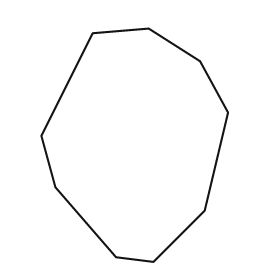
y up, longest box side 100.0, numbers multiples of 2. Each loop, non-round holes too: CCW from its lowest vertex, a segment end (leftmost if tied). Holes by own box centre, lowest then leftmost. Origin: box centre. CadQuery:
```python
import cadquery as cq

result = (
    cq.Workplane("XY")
    .moveTo(8.0, -50.0)
    .lineTo(30.0, -28.0)
    .lineTo(40.0, 14.0)
    .lineTo(28.0, 36.0)
    .lineTo(6.0, 50.0)
    .lineTo(-18.0, 48.0)
    .lineTo(-40.0, 4.0)
    .lineTo(-34.0, -18.0)
    .lineTo(-8.0, -48.0)
    .close()
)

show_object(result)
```